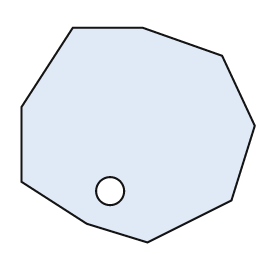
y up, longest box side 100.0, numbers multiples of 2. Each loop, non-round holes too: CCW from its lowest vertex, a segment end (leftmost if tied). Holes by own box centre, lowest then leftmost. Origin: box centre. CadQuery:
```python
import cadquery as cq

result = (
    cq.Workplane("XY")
    .moveTo(4.0, -46.0)
    .lineTo(40.0, -28.0)
    .lineTo(50.0, 4.0)
    .lineTo(36.0, 34.0)
    .lineTo(2.0, 46.0)
    .lineTo(-28.0, 46.0)
    .lineTo(-50.0, 12.0)
    .lineTo(-50.0, -20.0)
    .lineTo(-22.0, -38.0)
    .close()
    .moveTo(-12.0, -24.0)
    .circle(6.0)
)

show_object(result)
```